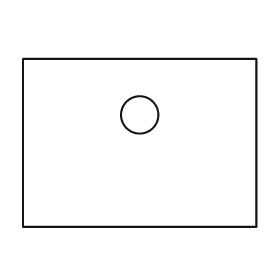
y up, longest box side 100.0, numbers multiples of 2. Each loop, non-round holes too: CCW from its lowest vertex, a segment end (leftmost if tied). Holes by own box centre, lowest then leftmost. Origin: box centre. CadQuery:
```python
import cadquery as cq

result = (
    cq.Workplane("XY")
    .moveTo(-50.0, -36.0)
    .lineTo(50.0, -36.0)
    .lineTo(50.0, 36.0)
    .lineTo(-50.0, 36.0)
    .close()
    .moveTo(0.0, 12.0)
    .circle(8.0)
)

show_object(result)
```